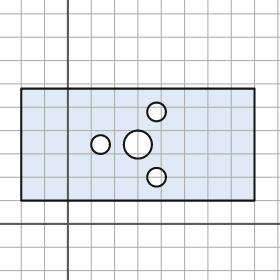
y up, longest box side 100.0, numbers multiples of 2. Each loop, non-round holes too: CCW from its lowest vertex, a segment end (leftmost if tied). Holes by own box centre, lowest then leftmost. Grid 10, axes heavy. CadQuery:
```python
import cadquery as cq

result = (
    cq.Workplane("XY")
    .moveTo(-20.0, 10.0)
    .lineTo(80.0, 10.0)
    .lineTo(80.0, 58.0)
    .lineTo(-20.0, 58.0)
    .close()
    .moveTo(38.0, 20.0)
    .circle(4.0)
    .moveTo(14.0, 34.0)
    .circle(4.0)
    .moveTo(30.0, 34.0)
    .circle(6.0)
    .moveTo(38.0, 48.0)
    .circle(4.0)
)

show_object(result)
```